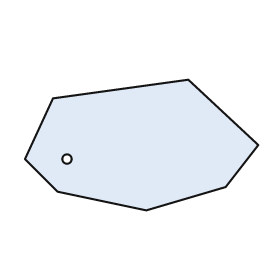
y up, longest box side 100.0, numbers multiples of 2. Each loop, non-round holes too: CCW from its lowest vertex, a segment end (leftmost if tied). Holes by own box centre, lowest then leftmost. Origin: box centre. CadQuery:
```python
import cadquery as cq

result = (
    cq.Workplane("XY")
    .moveTo(2.0, -28.0)
    .lineTo(36.0, -18.0)
    .lineTo(50.0, 0.0)
    .lineTo(20.0, 28.0)
    .lineTo(-38.0, 20.0)
    .lineTo(-50.0, -6.0)
    .lineTo(-36.0, -20.0)
    .close()
    .moveTo(-32.0, -6.0)
    .circle(2.0)
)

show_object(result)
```